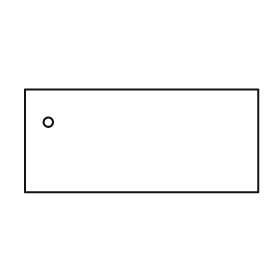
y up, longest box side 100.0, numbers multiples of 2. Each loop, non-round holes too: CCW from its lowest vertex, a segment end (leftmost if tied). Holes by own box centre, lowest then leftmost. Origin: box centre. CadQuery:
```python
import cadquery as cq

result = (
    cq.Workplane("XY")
    .moveTo(-50.0, -22.0)
    .lineTo(50.0, -22.0)
    .lineTo(50.0, 22.0)
    .lineTo(-50.0, 22.0)
    .close()
    .moveTo(-40.0, 8.0)
    .circle(2.0)
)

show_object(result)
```